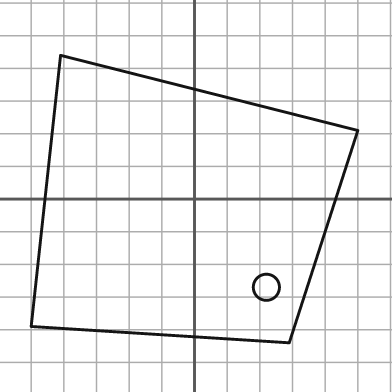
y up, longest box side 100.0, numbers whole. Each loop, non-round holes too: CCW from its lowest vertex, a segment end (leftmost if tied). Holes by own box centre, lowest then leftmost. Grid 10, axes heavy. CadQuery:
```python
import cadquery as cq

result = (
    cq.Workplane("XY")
    .moveTo(29.0, -44.0)
    .lineTo(50.0, 21.0)
    .lineTo(-41.0, 44.0)
    .lineTo(-50.0, -39.0)
    .close()
    .moveTo(22.0, -27.0)
    .circle(4.0)
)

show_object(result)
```